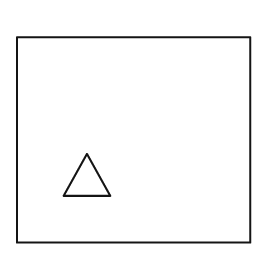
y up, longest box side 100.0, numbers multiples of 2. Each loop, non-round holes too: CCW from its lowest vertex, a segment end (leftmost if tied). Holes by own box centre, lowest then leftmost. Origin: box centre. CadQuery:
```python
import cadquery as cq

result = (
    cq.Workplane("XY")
    .moveTo(-50.0, -44.0)
    .lineTo(50.0, -44.0)
    .lineTo(50.0, 44.0)
    .lineTo(-50.0, 44.0)
    .close()
    .moveTo(-30.0, -24.0)
    .lineTo(-10.0, -24.0)
    .lineTo(-20.0, -6.0)
    .close()
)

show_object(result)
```